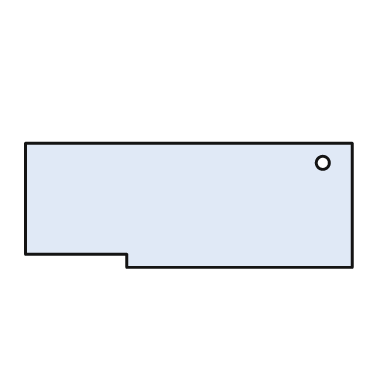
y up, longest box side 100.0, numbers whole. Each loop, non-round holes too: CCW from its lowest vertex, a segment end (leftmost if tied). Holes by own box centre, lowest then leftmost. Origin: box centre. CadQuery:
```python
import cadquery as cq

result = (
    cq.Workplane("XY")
    .moveTo(-19.0, -19.0)
    .lineTo(50.0, -19.0)
    .lineTo(50.0, 19.0)
    .lineTo(-50.0, 19.0)
    .lineTo(-50.0, -15.0)
    .lineTo(-19.0, -15.0)
    .close()
    .moveTo(41.0, 13.0)
    .circle(2.0)
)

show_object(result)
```